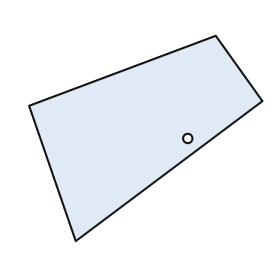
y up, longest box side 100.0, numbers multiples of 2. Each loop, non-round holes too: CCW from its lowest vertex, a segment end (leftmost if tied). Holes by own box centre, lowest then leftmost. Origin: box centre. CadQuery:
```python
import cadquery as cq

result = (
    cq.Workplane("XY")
    .moveTo(-30.0, -44.0)
    .lineTo(50.0, 16.0)
    .lineTo(30.0, 44.0)
    .lineTo(-50.0, 14.0)
    .close()
    .moveTo(18.0, 0.0)
    .circle(2.0)
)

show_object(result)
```